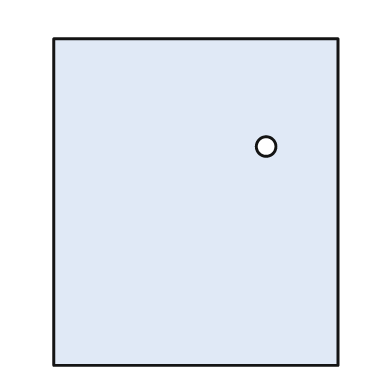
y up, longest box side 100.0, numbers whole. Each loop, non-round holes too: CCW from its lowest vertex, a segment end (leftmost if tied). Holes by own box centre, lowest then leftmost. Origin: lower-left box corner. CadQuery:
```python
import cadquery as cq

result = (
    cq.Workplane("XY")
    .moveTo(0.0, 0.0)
    .lineTo(87.0, 0.0)
    .lineTo(87.0, 100.0)
    .lineTo(0.0, 100.0)
    .close()
    .moveTo(65.0, 67.0)
    .circle(3.0)
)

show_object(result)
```